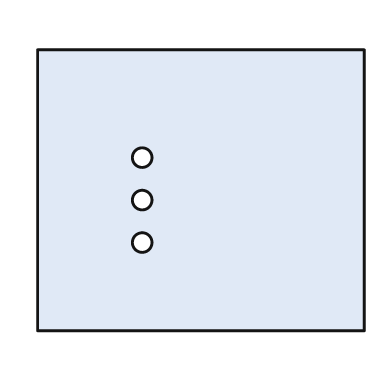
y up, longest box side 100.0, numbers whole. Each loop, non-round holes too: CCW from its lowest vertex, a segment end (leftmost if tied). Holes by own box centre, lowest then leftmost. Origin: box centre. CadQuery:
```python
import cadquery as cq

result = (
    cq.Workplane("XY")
    .moveTo(-50.0, -43.0)
    .lineTo(50.0, -43.0)
    .lineTo(50.0, 43.0)
    .lineTo(-50.0, 43.0)
    .close()
    .moveTo(-18.0, -16.0)
    .circle(3.0)
    .moveTo(-18.0, -3.0)
    .circle(3.0)
    .moveTo(-18.0, 10.0)
    .circle(3.0)
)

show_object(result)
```